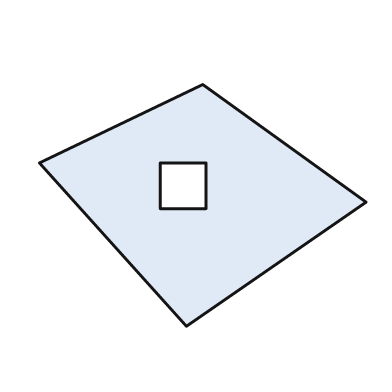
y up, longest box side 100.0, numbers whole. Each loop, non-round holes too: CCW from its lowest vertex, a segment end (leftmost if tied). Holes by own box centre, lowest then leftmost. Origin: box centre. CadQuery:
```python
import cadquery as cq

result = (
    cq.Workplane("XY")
    .moveTo(-5.0, -37.0)
    .lineTo(50.0, 1.0)
    .lineTo(0.0, 37.0)
    .lineTo(-50.0, 13.0)
    .close()
    .moveTo(-13.0, -1.0)
    .lineTo(1.0, -1.0)
    .lineTo(1.0, 13.0)
    .lineTo(-13.0, 13.0)
    .close()
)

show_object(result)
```